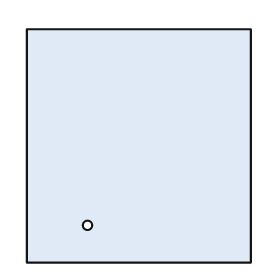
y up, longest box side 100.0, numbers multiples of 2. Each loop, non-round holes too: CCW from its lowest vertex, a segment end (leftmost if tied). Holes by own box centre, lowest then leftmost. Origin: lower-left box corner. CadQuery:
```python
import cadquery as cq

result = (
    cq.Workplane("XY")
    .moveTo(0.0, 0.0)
    .lineTo(96.0, 0.0)
    .lineTo(96.0, 100.0)
    .lineTo(0.0, 100.0)
    .close()
    .moveTo(26.0, 16.0)
    .circle(2.0)
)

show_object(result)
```